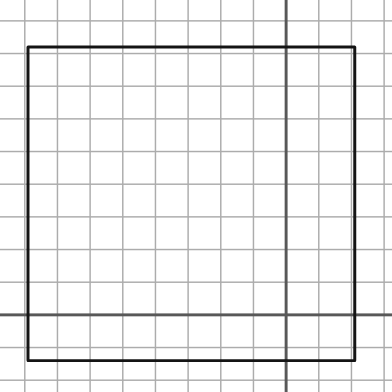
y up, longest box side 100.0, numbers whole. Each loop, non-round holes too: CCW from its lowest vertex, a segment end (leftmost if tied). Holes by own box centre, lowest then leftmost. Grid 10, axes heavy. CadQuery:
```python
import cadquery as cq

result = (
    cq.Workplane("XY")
    .moveTo(-79.0, -14.0)
    .lineTo(21.0, -14.0)
    .lineTo(21.0, 82.0)
    .lineTo(-79.0, 82.0)
    .close()
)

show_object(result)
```